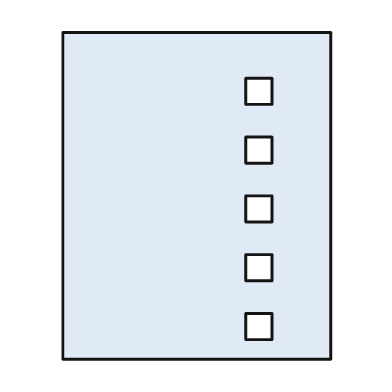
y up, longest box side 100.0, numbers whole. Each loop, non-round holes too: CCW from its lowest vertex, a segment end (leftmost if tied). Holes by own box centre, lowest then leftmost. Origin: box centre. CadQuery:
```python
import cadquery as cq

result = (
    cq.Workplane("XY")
    .moveTo(-41.0, -50.0)
    .lineTo(41.0, -50.0)
    .lineTo(41.0, 50.0)
    .lineTo(-41.0, 50.0)
    .close()
    .moveTo(15.0, -44.0)
    .lineTo(23.0, -44.0)
    .lineTo(23.0, -36.0)
    .lineTo(15.0, -36.0)
    .close()
    .moveTo(15.0, -26.0)
    .lineTo(23.0, -26.0)
    .lineTo(23.0, -18.0)
    .lineTo(15.0, -18.0)
    .close()
    .moveTo(15.0, -8.0)
    .lineTo(23.0, -8.0)
    .lineTo(23.0, 0.0)
    .lineTo(15.0, 0.0)
    .close()
    .moveTo(15.0, 10.0)
    .lineTo(23.0, 10.0)
    .lineTo(23.0, 18.0)
    .lineTo(15.0, 18.0)
    .close()
    .moveTo(15.0, 28.0)
    .lineTo(23.0, 28.0)
    .lineTo(23.0, 36.0)
    .lineTo(15.0, 36.0)
    .close()
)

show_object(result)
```